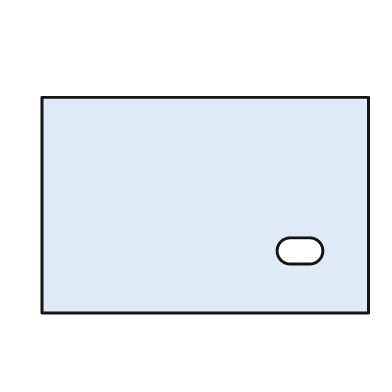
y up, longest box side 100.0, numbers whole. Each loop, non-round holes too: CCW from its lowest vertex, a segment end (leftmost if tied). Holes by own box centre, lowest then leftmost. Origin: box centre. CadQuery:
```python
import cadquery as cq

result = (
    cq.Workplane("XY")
    .moveTo(-50.0, -33.0)
    .lineTo(50.0, -33.0)
    .lineTo(50.0, 33.0)
    .lineTo(-50.0, 33.0)
    .close()
    .moveTo(26.0, -18.0)
    .lineTo(32.0, -18.0)
    .threePointArc((36.0, -14.0), (32.0, -10.0))
    .lineTo(26.0, -10.0)
    .threePointArc((22.0, -14.0), (26.0, -18.0))
    .close()
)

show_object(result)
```